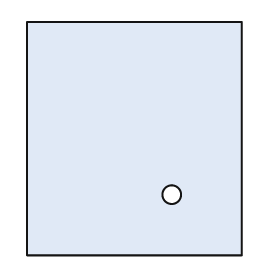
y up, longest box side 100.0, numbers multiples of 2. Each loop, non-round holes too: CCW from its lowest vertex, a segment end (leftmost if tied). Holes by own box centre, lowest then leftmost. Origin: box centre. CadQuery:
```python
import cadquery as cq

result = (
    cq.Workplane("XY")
    .moveTo(-46.0, -50.0)
    .lineTo(46.0, -50.0)
    .lineTo(46.0, 50.0)
    .lineTo(-46.0, 50.0)
    .close()
    .moveTo(16.0, -24.0)
    .circle(4.0)
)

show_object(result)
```